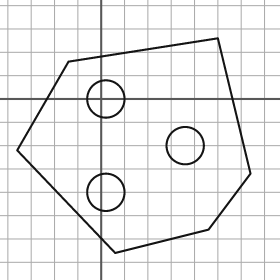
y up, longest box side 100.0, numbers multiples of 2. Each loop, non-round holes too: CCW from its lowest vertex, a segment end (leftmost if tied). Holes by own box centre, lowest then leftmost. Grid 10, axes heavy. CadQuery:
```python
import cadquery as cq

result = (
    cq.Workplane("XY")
    .moveTo(6.0, -66.0)
    .lineTo(46.0, -56.0)
    .lineTo(64.0, -32.0)
    .lineTo(50.0, 26.0)
    .lineTo(-14.0, 16.0)
    .lineTo(-36.0, -22.0)
    .close()
    .moveTo(2.0, -40.0)
    .circle(8.0)
    .moveTo(36.0, -20.0)
    .circle(8.0)
    .moveTo(2.0, 0.0)
    .circle(8.0)
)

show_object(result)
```